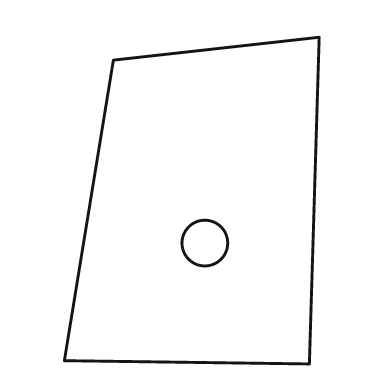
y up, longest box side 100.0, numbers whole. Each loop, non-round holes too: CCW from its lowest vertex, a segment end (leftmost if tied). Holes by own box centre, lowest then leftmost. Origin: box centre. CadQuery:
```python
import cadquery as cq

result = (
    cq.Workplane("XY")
    .moveTo(36.0, -50.0)
    .lineTo(39.0, 50.0)
    .lineTo(-24.0, 43.0)
    .lineTo(-39.0, -49.0)
    .close()
    .moveTo(4.0, -13.0)
    .circle(7.0)
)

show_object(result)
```